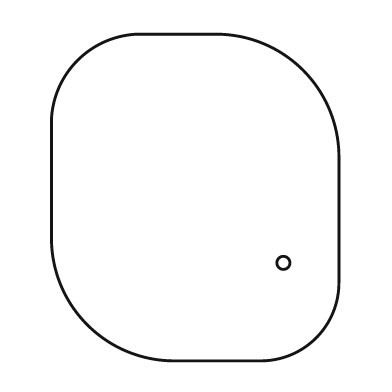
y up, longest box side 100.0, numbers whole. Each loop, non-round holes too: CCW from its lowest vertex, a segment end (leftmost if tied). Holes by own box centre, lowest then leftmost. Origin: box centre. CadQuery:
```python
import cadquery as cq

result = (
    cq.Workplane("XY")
    .moveTo(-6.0, -50.0)
    .lineTo(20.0, -50.0)
    .threePointArc((37.0, -43.0), (44.0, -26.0))
    .lineTo(44.0, 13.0)
    .threePointArc((33.0, 39.0), (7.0, 50.0))
    .lineTo(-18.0, 50.0)
    .threePointArc((-36.0, 42.0), (-44.0, 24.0))
    .lineTo(-44.0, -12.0)
    .threePointArc((-33.0, -39.0), (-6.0, -50.0))
    .close()
    .moveTo(27.0, -20.0)
    .circle(2.0)
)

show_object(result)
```